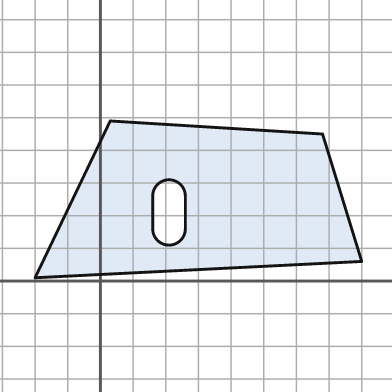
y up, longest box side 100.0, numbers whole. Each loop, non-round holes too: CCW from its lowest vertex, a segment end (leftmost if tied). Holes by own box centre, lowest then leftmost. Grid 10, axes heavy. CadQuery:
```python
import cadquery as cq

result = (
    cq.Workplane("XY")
    .moveTo(-20.0, 1.0)
    .lineTo(80.0, 6.0)
    .lineTo(68.0, 45.0)
    .lineTo(3.0, 49.0)
    .close()
    .moveTo(16.0, 16.0)
    .threePointArc((21.0, 11.0), (26.0, 16.0))
    .lineTo(26.0, 26.0)
    .threePointArc((21.0, 31.0), (16.0, 26.0))
    .close()
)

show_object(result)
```